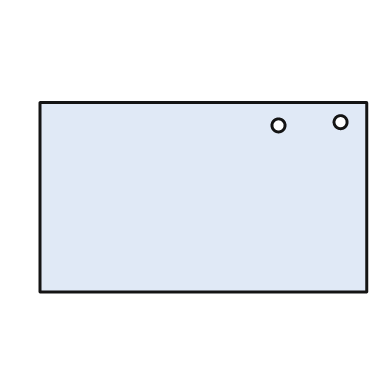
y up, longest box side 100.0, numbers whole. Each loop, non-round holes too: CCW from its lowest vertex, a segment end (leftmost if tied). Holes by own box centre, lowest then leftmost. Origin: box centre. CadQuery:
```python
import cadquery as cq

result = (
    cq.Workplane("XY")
    .moveTo(-50.0, -29.0)
    .lineTo(50.0, -29.0)
    .lineTo(50.0, 29.0)
    .lineTo(-50.0, 29.0)
    .close()
    .moveTo(23.0, 22.0)
    .circle(2.0)
    .moveTo(42.0, 23.0)
    .circle(2.0)
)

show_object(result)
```